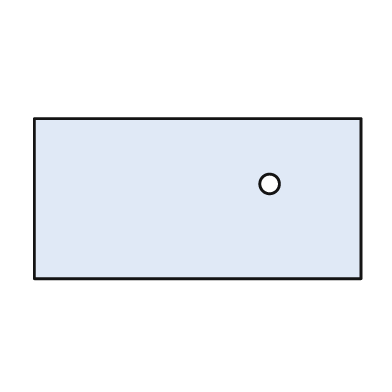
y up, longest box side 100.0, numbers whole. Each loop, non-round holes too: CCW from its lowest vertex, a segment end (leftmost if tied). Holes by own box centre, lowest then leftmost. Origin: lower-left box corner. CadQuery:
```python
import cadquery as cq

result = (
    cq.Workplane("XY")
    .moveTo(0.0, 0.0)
    .lineTo(100.0, 0.0)
    .lineTo(100.0, 49.0)
    .lineTo(0.0, 49.0)
    .close()
    .moveTo(72.0, 29.0)
    .circle(3.0)
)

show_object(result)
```